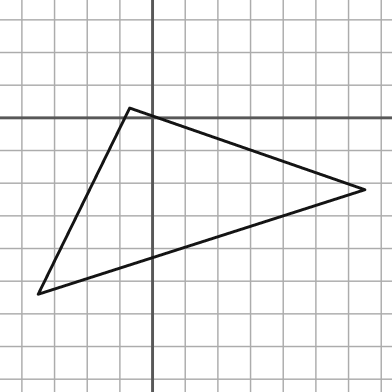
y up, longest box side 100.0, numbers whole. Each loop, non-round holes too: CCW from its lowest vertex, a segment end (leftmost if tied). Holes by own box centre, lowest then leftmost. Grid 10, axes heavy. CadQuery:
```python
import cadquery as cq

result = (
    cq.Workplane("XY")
    .moveTo(-35.0, -54.0)
    .lineTo(65.0, -22.0)
    .lineTo(-7.0, 3.0)
    .close()
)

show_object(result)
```